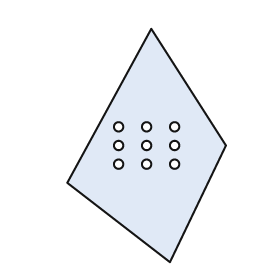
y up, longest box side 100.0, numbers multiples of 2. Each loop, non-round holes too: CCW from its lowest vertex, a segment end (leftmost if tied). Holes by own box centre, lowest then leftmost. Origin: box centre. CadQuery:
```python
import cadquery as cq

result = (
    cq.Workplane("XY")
    .moveTo(10.0, -50.0)
    .lineTo(34.0, 0.0)
    .lineTo(2.0, 50.0)
    .lineTo(-34.0, -16.0)
    .close()
    .moveTo(-12.0, -8.0)
    .circle(2.0)
    .moveTo(0.0, -8.0)
    .circle(2.0)
    .moveTo(12.0, -8.0)
    .circle(2.0)
    .moveTo(-12.0, 0.0)
    .circle(2.0)
    .moveTo(0.0, 0.0)
    .circle(2.0)
    .moveTo(12.0, 0.0)
    .circle(2.0)
    .moveTo(-12.0, 8.0)
    .circle(2.0)
    .moveTo(0.0, 8.0)
    .circle(2.0)
    .moveTo(12.0, 8.0)
    .circle(2.0)
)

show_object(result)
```